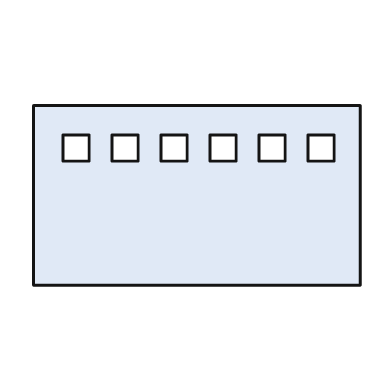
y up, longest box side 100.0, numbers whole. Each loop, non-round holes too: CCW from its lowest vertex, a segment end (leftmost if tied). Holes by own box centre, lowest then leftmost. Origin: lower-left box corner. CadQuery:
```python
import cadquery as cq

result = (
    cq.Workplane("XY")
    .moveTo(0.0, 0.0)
    .lineTo(100.0, 0.0)
    .lineTo(100.0, 55.0)
    .lineTo(0.0, 55.0)
    .close()
    .moveTo(9.0, 38.0)
    .lineTo(17.0, 38.0)
    .lineTo(17.0, 46.0)
    .lineTo(9.0, 46.0)
    .close()
    .moveTo(24.0, 38.0)
    .lineTo(32.0, 38.0)
    .lineTo(32.0, 46.0)
    .lineTo(24.0, 46.0)
    .close()
    .moveTo(39.0, 38.0)
    .lineTo(47.0, 38.0)
    .lineTo(47.0, 46.0)
    .lineTo(39.0, 46.0)
    .close()
    .moveTo(54.0, 38.0)
    .lineTo(62.0, 38.0)
    .lineTo(62.0, 46.0)
    .lineTo(54.0, 46.0)
    .close()
    .moveTo(69.0, 38.0)
    .lineTo(77.0, 38.0)
    .lineTo(77.0, 46.0)
    .lineTo(69.0, 46.0)
    .close()
    .moveTo(84.0, 38.0)
    .lineTo(92.0, 38.0)
    .lineTo(92.0, 46.0)
    .lineTo(84.0, 46.0)
    .close()
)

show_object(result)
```